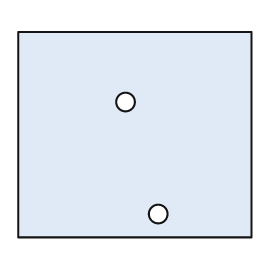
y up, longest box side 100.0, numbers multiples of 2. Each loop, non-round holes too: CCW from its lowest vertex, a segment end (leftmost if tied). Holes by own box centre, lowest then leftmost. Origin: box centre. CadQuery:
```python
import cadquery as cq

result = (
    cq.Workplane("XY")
    .moveTo(-50.0, -44.0)
    .lineTo(50.0, -44.0)
    .lineTo(50.0, 44.0)
    .lineTo(-50.0, 44.0)
    .close()
    .moveTo(10.0, -34.0)
    .circle(4.0)
    .moveTo(-4.0, 14.0)
    .circle(4.0)
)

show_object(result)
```